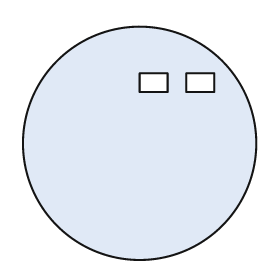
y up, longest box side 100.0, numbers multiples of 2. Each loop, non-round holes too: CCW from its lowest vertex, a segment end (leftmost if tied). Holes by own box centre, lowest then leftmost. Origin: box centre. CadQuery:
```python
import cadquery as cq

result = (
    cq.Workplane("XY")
    .moveTo(0.0, 0.0)
    .circle(50.0)
    .moveTo(0.0, 22.0)
    .lineTo(12.0, 22.0)
    .lineTo(12.0, 30.0)
    .lineTo(0.0, 30.0)
    .close()
    .moveTo(20.0, 22.0)
    .lineTo(32.0, 22.0)
    .lineTo(32.0, 30.0)
    .lineTo(20.0, 30.0)
    .close()
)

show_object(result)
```